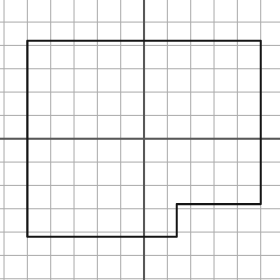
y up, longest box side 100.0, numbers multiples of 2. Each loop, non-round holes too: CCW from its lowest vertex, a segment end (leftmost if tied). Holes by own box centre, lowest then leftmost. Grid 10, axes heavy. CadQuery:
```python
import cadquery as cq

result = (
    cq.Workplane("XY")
    .moveTo(-50.0, -42.0)
    .lineTo(14.0, -42.0)
    .lineTo(14.0, -28.0)
    .lineTo(50.0, -28.0)
    .lineTo(50.0, 42.0)
    .lineTo(-50.0, 42.0)
    .close()
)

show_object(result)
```